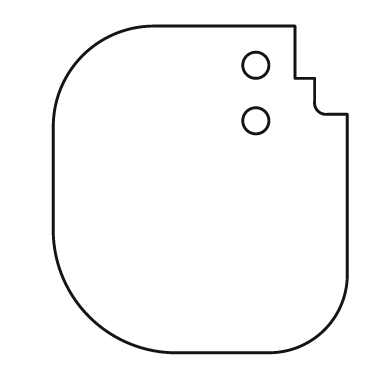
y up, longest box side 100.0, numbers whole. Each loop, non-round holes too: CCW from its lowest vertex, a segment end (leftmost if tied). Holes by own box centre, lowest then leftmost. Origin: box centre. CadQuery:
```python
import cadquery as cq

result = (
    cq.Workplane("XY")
    .moveTo(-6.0, -50.0)
    .lineTo(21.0, -50.0)
    .threePointArc((38.0, -43.0), (45.0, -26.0))
    .lineTo(45.0, 23.0)
    .lineTo(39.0, 23.0)
    .threePointArc((36.0, 24.0), (35.0, 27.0))
    .lineTo(35.0, 34.0)
    .lineTo(29.0, 34.0)
    .lineTo(29.0, 50.0)
    .lineTo(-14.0, 50.0)
    .threePointArc((-36.0, 41.0), (-45.0, 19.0))
    .lineTo(-45.0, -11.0)
    .threePointArc((-34.0, -39.0), (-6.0, -50.0))
    .close()
    .moveTo(17.0, 21.0)
    .circle(4.0)
    .moveTo(17.0, 38.0)
    .circle(4.0)
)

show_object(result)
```